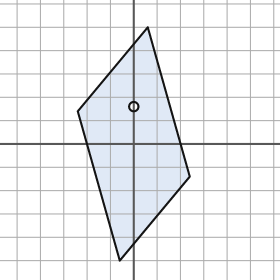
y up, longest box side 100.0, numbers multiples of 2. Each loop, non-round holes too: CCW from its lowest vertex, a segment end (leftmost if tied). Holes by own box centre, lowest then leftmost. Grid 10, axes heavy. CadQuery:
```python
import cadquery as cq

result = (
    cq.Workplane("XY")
    .moveTo(-6.0, -50.0)
    .lineTo(24.0, -14.0)
    .lineTo(6.0, 50.0)
    .lineTo(-24.0, 14.0)
    .close()
    .moveTo(0.0, 16.0)
    .circle(2.0)
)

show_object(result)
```